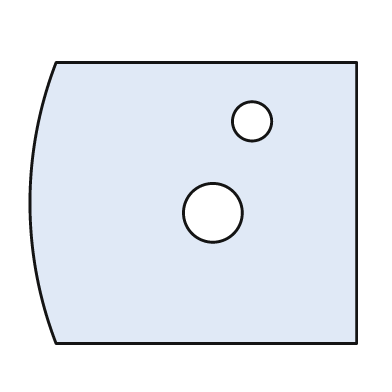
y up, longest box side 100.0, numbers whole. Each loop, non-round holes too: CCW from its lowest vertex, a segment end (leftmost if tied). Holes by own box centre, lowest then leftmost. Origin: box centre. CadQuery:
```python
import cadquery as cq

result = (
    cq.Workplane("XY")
    .moveTo(-42.0, -43.0)
    .lineTo(50.0, -43.0)
    .lineTo(50.0, 43.0)
    .lineTo(-42.0, 43.0)
    .threePointArc((-50.0, 0.0), (-42.0, -43.0))
    .close()
    .moveTo(6.0, -3.0)
    .circle(9.0)
    .moveTo(18.0, 25.0)
    .circle(6.0)
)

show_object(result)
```